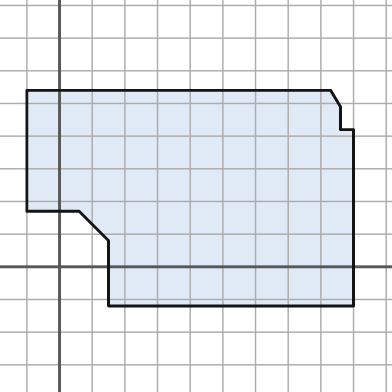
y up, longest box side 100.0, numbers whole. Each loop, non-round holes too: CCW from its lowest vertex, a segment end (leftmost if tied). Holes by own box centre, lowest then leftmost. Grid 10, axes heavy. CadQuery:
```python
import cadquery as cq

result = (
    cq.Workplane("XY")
    .moveTo(15.0, -12.0)
    .lineTo(90.0, -12.0)
    .lineTo(90.0, 42.0)
    .lineTo(86.0, 42.0)
    .lineTo(86.0, 49.0)
    .lineTo(83.0, 54.0)
    .lineTo(-10.0, 54.0)
    .lineTo(-10.0, 17.0)
    .lineTo(6.0, 17.0)
    .lineTo(15.0, 8.0)
    .close()
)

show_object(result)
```